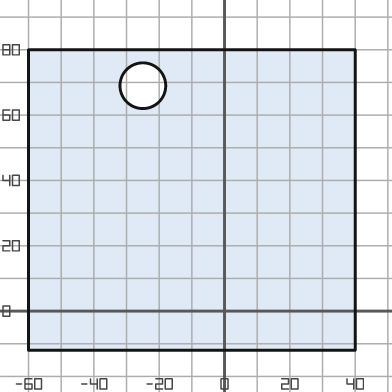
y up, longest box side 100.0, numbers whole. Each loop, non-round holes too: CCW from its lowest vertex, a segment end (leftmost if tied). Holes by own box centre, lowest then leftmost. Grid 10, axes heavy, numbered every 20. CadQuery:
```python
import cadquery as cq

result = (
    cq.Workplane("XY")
    .moveTo(-60.0, -12.0)
    .lineTo(40.0, -12.0)
    .lineTo(40.0, 80.0)
    .lineTo(-60.0, 80.0)
    .close()
    .moveTo(-25.0, 69.0)
    .circle(7.0)
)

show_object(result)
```